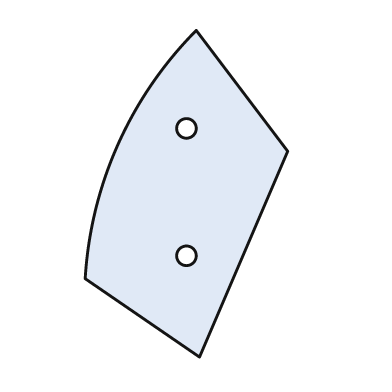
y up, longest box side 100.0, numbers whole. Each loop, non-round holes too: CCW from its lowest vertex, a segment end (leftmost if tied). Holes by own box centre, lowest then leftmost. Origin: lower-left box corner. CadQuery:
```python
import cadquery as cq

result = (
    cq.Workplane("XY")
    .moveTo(35.0, 0.0)
    .lineTo(62.0, 63.0)
    .lineTo(34.0, 100.0)
    .threePointArc((10.0, 65.0), (0.0, 24.0))
    .close()
    .moveTo(31.0, 31.0)
    .circle(3.0)
    .moveTo(31.0, 70.0)
    .circle(3.0)
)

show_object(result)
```